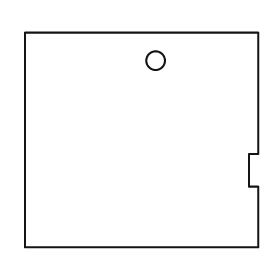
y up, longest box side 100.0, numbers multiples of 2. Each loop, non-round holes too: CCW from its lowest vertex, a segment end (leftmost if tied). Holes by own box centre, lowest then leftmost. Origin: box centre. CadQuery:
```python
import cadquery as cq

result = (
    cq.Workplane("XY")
    .moveTo(-50.0, -46.0)
    .lineTo(50.0, -46.0)
    .lineTo(50.0, -20.0)
    .lineTo(46.0, -20.0)
    .lineTo(46.0, -6.0)
    .lineTo(50.0, -6.0)
    .lineTo(50.0, 46.0)
    .lineTo(-50.0, 46.0)
    .close()
    .moveTo(6.0, 34.0)
    .circle(4.0)
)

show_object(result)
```